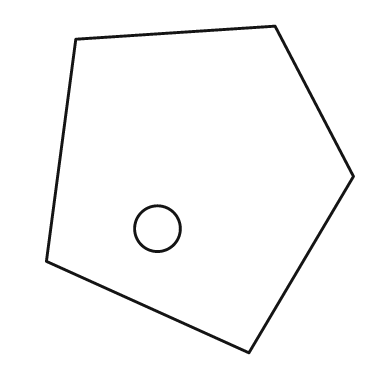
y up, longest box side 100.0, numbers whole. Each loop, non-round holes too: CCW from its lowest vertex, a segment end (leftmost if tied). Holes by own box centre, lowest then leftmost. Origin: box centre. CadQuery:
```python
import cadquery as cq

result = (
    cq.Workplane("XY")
    .moveTo(15.0, -50.0)
    .lineTo(47.0, 4.0)
    .lineTo(23.0, 50.0)
    .lineTo(-38.0, 46.0)
    .lineTo(-47.0, -22.0)
    .close()
    .moveTo(-13.0, -12.0)
    .circle(7.0)
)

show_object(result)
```